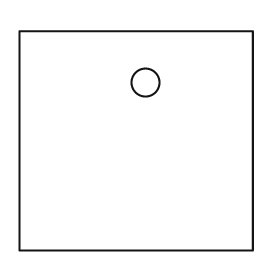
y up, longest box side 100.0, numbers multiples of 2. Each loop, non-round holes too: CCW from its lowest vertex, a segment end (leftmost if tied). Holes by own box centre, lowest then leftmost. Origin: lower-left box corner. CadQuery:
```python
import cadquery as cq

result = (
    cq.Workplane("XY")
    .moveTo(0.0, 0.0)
    .lineTo(100.0, 0.0)
    .lineTo(100.0, 94.0)
    .lineTo(0.0, 94.0)
    .close()
    .moveTo(54.0, 72.0)
    .circle(6.0)
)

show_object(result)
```